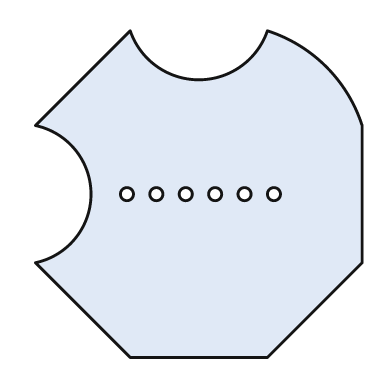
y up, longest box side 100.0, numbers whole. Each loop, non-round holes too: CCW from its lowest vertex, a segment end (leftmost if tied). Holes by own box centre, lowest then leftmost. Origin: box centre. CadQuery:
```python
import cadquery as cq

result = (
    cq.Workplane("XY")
    .moveTo(-21.0, -50.0)
    .lineTo(21.0, -50.0)
    .lineTo(50.0, -21.0)
    .lineTo(50.0, 21.0)
    .threePointArc((39.0, 39.0), (21.0, 50.0))
    .threePointArc((0.0, 35.0), (-21.0, 50.0))
    .lineTo(-50.0, 21.0)
    .threePointArc((-33.0, 0.0), (-50.0, -21.0))
    .close()
    .moveTo(-22.0, 0.0)
    .circle(2.0)
    .moveTo(-13.0, 0.0)
    .circle(2.0)
    .moveTo(-4.0, 0.0)
    .circle(2.0)
    .moveTo(5.0, 0.0)
    .circle(2.0)
    .moveTo(14.0, 0.0)
    .circle(2.0)
    .moveTo(23.0, 0.0)
    .circle(2.0)
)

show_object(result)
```